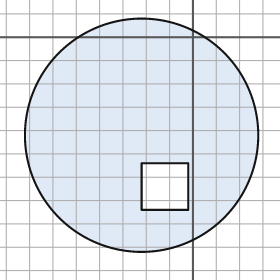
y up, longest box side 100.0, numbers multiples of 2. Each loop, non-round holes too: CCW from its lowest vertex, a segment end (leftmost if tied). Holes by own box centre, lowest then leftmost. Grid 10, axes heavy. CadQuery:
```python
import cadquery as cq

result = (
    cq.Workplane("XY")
    .moveTo(-22.0, -42.0)
    .circle(50.0)
    .moveTo(-22.0, -74.0)
    .lineTo(-2.0, -74.0)
    .lineTo(-2.0, -54.0)
    .lineTo(-22.0, -54.0)
    .close()
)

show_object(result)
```